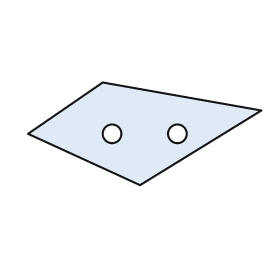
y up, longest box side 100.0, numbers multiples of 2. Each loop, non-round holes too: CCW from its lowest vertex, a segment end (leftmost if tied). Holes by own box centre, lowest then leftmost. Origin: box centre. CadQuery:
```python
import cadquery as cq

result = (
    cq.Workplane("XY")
    .moveTo(-2.0, -22.0)
    .lineTo(50.0, 10.0)
    .lineTo(-18.0, 22.0)
    .lineTo(-50.0, 0.0)
    .close()
    .moveTo(-14.0, 0.0)
    .circle(4.0)
    .moveTo(14.0, 0.0)
    .circle(4.0)
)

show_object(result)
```